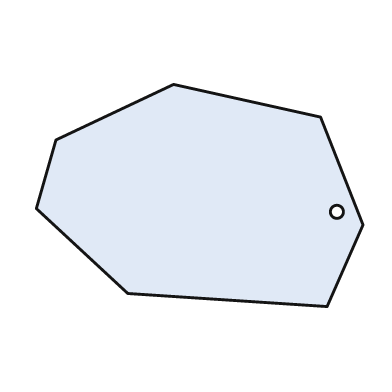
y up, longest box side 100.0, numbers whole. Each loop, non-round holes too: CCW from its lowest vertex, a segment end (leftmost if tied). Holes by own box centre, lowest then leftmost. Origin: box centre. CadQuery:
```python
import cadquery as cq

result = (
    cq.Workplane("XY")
    .moveTo(39.0, -34.0)
    .lineTo(50.0, -9.0)
    .lineTo(37.0, 24.0)
    .lineTo(-8.0, 34.0)
    .lineTo(-44.0, 17.0)
    .lineTo(-50.0, -4.0)
    .lineTo(-22.0, -30.0)
    .close()
    .moveTo(42.0, -5.0)
    .circle(2.0)
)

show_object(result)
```